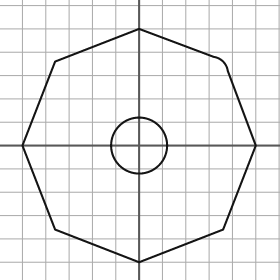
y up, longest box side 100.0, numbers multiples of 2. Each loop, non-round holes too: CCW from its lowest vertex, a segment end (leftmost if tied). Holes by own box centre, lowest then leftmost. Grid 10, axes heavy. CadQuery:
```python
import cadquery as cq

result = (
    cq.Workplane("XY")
    .moveTo(0.0, -50.0)
    .lineTo(36.0, -36.0)
    .lineTo(50.0, 0.0)
    .lineTo(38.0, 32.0)
    .threePointArc((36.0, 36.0), (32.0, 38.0))
    .lineTo(0.0, 50.0)
    .lineTo(-36.0, 36.0)
    .lineTo(-50.0, 0.0)
    .lineTo(-36.0, -36.0)
    .close()
    .moveTo(0.0, 0.0)
    .circle(12.0)
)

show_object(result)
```